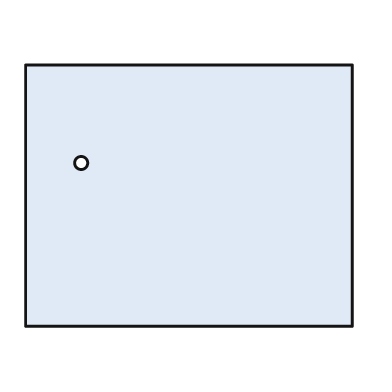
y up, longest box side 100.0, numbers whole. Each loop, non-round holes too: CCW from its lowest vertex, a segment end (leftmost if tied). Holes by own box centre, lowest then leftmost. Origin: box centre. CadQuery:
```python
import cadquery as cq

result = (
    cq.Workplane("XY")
    .moveTo(-50.0, -40.0)
    .lineTo(50.0, -40.0)
    .lineTo(50.0, 40.0)
    .lineTo(-50.0, 40.0)
    .close()
    .moveTo(-33.0, 10.0)
    .circle(2.0)
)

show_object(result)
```